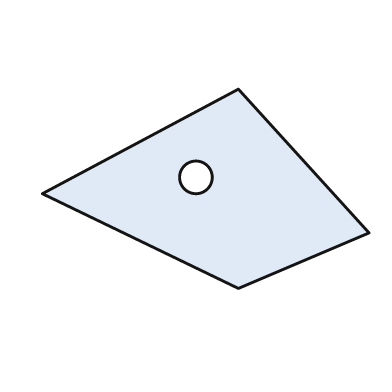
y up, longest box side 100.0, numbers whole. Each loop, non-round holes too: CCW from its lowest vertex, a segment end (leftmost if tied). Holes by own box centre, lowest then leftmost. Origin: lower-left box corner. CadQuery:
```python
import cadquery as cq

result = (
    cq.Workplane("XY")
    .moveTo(60.0, 0.0)
    .lineTo(100.0, 17.0)
    .lineTo(60.0, 61.0)
    .lineTo(0.0, 29.0)
    .close()
    .moveTo(47.0, 34.0)
    .circle(5.0)
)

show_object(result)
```